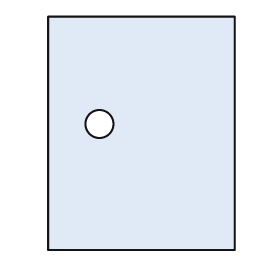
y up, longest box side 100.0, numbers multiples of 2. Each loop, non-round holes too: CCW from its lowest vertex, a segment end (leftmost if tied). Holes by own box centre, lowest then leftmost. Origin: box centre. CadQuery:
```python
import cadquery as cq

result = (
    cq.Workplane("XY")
    .moveTo(-40.0, -50.0)
    .lineTo(40.0, -50.0)
    .lineTo(40.0, 50.0)
    .lineTo(-40.0, 50.0)
    .close()
    .moveTo(-18.0, 4.0)
    .circle(6.0)
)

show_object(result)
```